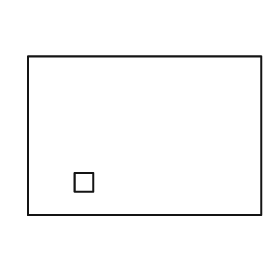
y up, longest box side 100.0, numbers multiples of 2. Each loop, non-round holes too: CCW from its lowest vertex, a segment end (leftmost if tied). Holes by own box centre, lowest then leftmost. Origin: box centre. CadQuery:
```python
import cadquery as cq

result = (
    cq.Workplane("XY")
    .moveTo(-50.0, -34.0)
    .lineTo(50.0, -34.0)
    .lineTo(50.0, 34.0)
    .lineTo(-50.0, 34.0)
    .close()
    .moveTo(-30.0, -24.0)
    .lineTo(-22.0, -24.0)
    .lineTo(-22.0, -16.0)
    .lineTo(-30.0, -16.0)
    .close()
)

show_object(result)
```